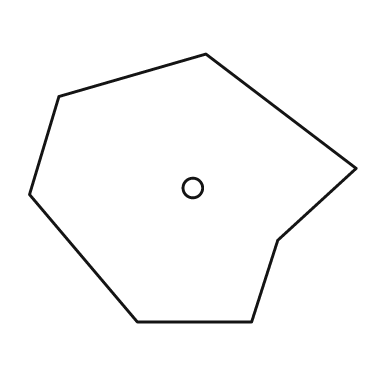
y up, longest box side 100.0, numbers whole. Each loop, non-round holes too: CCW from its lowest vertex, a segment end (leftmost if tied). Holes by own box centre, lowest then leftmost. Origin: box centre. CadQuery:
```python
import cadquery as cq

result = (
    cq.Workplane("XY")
    .moveTo(-17.0, -41.0)
    .lineTo(18.0, -41.0)
    .lineTo(26.0, -16.0)
    .lineTo(50.0, 6.0)
    .lineTo(4.0, 41.0)
    .lineTo(-41.0, 28.0)
    .lineTo(-50.0, -2.0)
    .close()
    .moveTo(0.0, 0.0)
    .circle(3.0)
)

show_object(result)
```